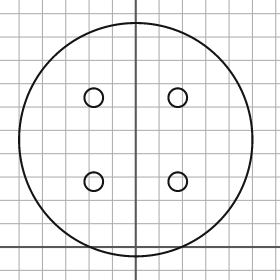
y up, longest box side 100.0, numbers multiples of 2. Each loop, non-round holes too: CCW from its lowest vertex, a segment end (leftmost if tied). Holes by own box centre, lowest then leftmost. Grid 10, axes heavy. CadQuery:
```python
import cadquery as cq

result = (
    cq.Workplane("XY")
    .moveTo(0.0, 46.0)
    .circle(50.0)
    .moveTo(-18.0, 28.0)
    .circle(4.0)
    .moveTo(18.0, 28.0)
    .circle(4.0)
    .moveTo(-18.0, 64.0)
    .circle(4.0)
    .moveTo(18.0, 64.0)
    .circle(4.0)
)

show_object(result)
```